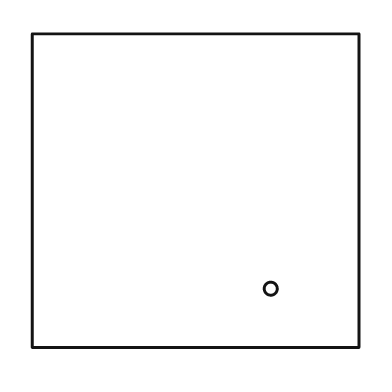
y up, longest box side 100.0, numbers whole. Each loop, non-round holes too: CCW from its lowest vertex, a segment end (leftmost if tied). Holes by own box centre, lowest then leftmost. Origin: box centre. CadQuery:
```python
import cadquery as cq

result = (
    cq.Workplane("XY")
    .moveTo(-50.0, -48.0)
    .lineTo(50.0, -48.0)
    .lineTo(50.0, 48.0)
    .lineTo(-50.0, 48.0)
    .close()
    .moveTo(23.0, -30.0)
    .circle(2.0)
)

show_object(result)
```